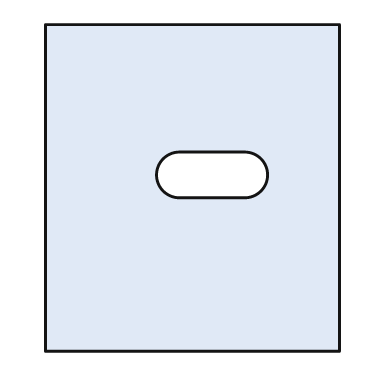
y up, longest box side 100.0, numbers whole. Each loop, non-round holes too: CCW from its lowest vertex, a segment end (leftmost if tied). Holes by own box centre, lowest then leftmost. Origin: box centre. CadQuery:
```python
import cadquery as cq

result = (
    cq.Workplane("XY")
    .moveTo(-45.0, -50.0)
    .lineTo(45.0, -50.0)
    .lineTo(45.0, 50.0)
    .lineTo(-45.0, 50.0)
    .close()
    .moveTo(-4.0, -3.0)
    .lineTo(16.0, -3.0)
    .threePointArc((23.0, 4.0), (16.0, 11.0))
    .lineTo(-4.0, 11.0)
    .threePointArc((-11.0, 4.0), (-4.0, -3.0))
    .close()
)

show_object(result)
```